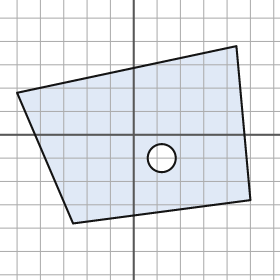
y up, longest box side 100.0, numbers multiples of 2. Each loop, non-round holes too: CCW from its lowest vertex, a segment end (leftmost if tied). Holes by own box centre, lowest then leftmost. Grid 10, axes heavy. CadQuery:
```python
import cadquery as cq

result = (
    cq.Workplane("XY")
    .moveTo(-26.0, -38.0)
    .lineTo(50.0, -28.0)
    .lineTo(44.0, 38.0)
    .lineTo(-50.0, 18.0)
    .close()
    .moveTo(12.0, -10.0)
    .circle(6.0)
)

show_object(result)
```